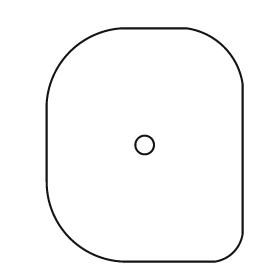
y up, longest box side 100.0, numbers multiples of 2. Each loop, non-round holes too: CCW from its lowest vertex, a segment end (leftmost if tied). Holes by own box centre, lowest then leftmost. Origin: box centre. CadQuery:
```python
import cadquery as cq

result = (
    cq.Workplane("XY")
    .moveTo(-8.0, -50.0)
    .lineTo(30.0, -50.0)
    .threePointArc((38.0, -46.0), (42.0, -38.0))
    .lineTo(42.0, 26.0)
    .threePointArc((34.0, 42.0), (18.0, 50.0))
    .lineTo(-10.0, 50.0)
    .threePointArc((-32.0, 40.0), (-42.0, 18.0))
    .lineTo(-42.0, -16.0)
    .threePointArc((-32.0, -40.0), (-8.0, -50.0))
    .close()
    .moveTo(0.0, 0.0)
    .circle(4.0)
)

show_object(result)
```